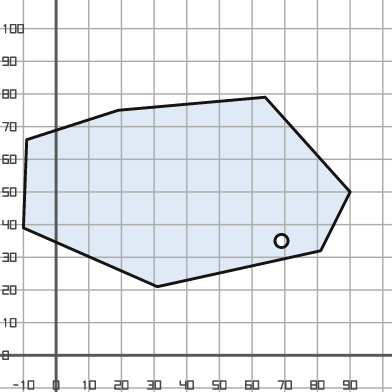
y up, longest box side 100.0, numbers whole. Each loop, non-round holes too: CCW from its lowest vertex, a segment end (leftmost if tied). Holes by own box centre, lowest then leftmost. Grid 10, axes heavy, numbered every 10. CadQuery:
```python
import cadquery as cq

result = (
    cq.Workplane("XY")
    .moveTo(31.0, 21.0)
    .lineTo(81.0, 32.0)
    .lineTo(90.0, 50.0)
    .lineTo(64.0, 79.0)
    .lineTo(19.0, 75.0)
    .lineTo(-9.0, 66.0)
    .lineTo(-10.0, 39.0)
    .close()
    .moveTo(69.0, 35.0)
    .circle(2.0)
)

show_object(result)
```